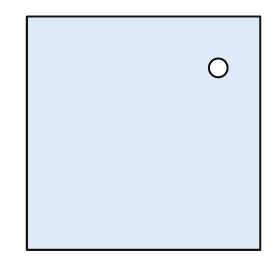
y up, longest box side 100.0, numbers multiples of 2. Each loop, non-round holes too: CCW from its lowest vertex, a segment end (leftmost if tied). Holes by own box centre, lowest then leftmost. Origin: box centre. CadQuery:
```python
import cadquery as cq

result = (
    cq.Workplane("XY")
    .moveTo(-50.0, -50.0)
    .lineTo(50.0, -50.0)
    .lineTo(50.0, 50.0)
    .lineTo(-50.0, 50.0)
    .close()
    .moveTo(32.0, 28.0)
    .circle(4.0)
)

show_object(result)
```